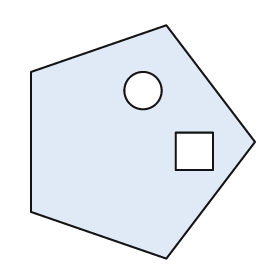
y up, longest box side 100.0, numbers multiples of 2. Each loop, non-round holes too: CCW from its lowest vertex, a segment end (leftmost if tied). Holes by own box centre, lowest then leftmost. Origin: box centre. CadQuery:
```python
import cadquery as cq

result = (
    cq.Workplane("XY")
    .moveTo(10.0, -50.0)
    .lineTo(48.0, 0.0)
    .lineTo(10.0, 50.0)
    .lineTo(-48.0, 30.0)
    .lineTo(-48.0, -30.0)
    .close()
    .moveTo(14.0, -12.0)
    .lineTo(30.0, -12.0)
    .lineTo(30.0, 4.0)
    .lineTo(14.0, 4.0)
    .close()
    .moveTo(0.0, 22.0)
    .circle(8.0)
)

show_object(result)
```